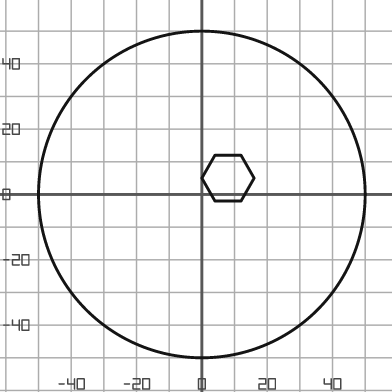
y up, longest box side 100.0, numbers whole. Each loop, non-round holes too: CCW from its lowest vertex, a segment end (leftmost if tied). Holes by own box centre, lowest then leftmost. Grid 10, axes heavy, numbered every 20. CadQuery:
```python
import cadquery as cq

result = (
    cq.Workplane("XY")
    .moveTo(0.0, 0.0)
    .circle(50.0)
    .moveTo(4.0, -2.0)
    .lineTo(12.0, -2.0)
    .lineTo(16.0, 5.0)
    .lineTo(12.0, 12.0)
    .lineTo(4.0, 12.0)
    .lineTo(0.0, 5.0)
    .close()
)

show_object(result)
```